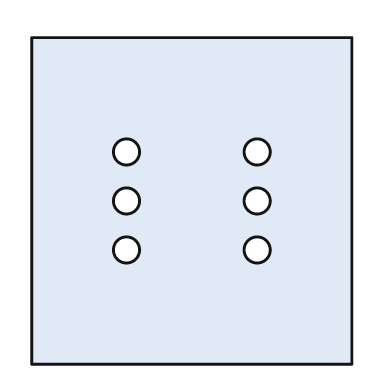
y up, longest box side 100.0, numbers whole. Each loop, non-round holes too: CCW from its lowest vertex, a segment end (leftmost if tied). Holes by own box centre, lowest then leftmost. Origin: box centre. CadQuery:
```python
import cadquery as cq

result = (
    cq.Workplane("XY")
    .moveTo(-49.0, -50.0)
    .lineTo(49.0, -50.0)
    .lineTo(49.0, 50.0)
    .lineTo(-49.0, 50.0)
    .close()
    .moveTo(-20.0, -15.0)
    .circle(4.0)
    .moveTo(20.0, -15.0)
    .circle(4.0)
    .moveTo(-20.0, 0.0)
    .circle(4.0)
    .moveTo(20.0, 0.0)
    .circle(4.0)
    .moveTo(-20.0, 15.0)
    .circle(4.0)
    .moveTo(20.0, 15.0)
    .circle(4.0)
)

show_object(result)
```